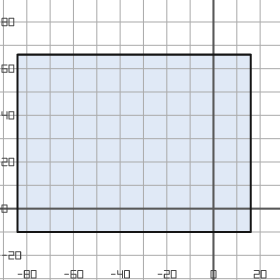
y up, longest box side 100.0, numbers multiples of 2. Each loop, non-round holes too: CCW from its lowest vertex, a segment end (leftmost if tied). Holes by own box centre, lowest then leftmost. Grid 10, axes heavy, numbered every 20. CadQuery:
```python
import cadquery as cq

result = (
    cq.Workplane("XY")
    .moveTo(-84.0, -10.0)
    .lineTo(16.0, -10.0)
    .lineTo(16.0, 66.0)
    .lineTo(-84.0, 66.0)
    .close()
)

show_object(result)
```